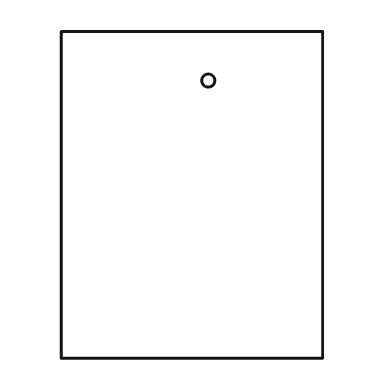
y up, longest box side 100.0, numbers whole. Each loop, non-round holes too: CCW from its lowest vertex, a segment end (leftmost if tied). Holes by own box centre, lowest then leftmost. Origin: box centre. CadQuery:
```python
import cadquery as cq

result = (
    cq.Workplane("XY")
    .moveTo(-40.0, -50.0)
    .lineTo(40.0, -50.0)
    .lineTo(40.0, 50.0)
    .lineTo(-40.0, 50.0)
    .close()
    .moveTo(5.0, 35.0)
    .circle(2.0)
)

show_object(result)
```